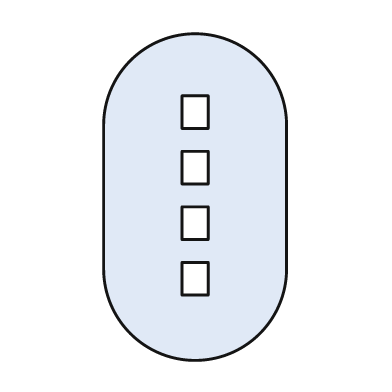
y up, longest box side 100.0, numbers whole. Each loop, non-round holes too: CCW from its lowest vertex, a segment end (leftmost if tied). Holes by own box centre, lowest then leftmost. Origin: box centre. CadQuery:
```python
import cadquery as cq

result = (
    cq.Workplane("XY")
    .moveTo(-28.0, -22.0)
    .threePointArc((0.0, -50.0), (28.0, -22.0))
    .lineTo(28.0, 22.0)
    .threePointArc((0.0, 50.0), (-28.0, 22.0))
    .close()
    .moveTo(-4.0, -30.0)
    .lineTo(4.0, -30.0)
    .lineTo(4.0, -20.0)
    .lineTo(-4.0, -20.0)
    .close()
    .moveTo(-4.0, -13.0)
    .lineTo(4.0, -13.0)
    .lineTo(4.0, -3.0)
    .lineTo(-4.0, -3.0)
    .close()
    .moveTo(-4.0, 4.0)
    .lineTo(4.0, 4.0)
    .lineTo(4.0, 14.0)
    .lineTo(-4.0, 14.0)
    .close()
    .moveTo(-4.0, 21.0)
    .lineTo(4.0, 21.0)
    .lineTo(4.0, 31.0)
    .lineTo(-4.0, 31.0)
    .close()
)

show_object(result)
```